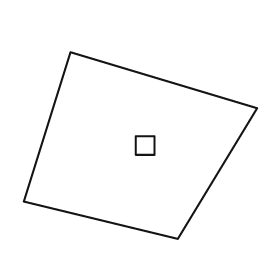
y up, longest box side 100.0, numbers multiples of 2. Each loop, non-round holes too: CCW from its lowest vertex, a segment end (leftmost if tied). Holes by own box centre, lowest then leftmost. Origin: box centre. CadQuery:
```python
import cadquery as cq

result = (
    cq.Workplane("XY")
    .moveTo(16.0, -40.0)
    .lineTo(50.0, 16.0)
    .lineTo(-30.0, 40.0)
    .lineTo(-50.0, -24.0)
    .close()
    .moveTo(-2.0, -4.0)
    .lineTo(6.0, -4.0)
    .lineTo(6.0, 4.0)
    .lineTo(-2.0, 4.0)
    .close()
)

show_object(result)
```